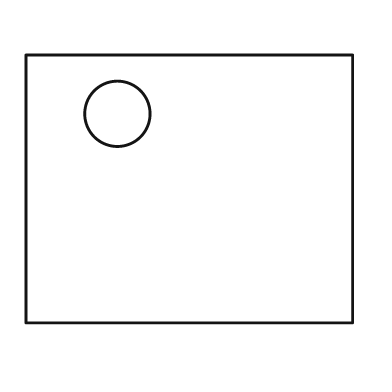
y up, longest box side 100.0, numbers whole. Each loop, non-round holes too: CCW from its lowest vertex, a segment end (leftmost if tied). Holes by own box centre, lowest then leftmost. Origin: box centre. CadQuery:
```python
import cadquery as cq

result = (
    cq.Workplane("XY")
    .moveTo(-50.0, -41.0)
    .lineTo(50.0, -41.0)
    .lineTo(50.0, 41.0)
    .lineTo(-50.0, 41.0)
    .close()
    .moveTo(-22.0, 23.0)
    .circle(10.0)
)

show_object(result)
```